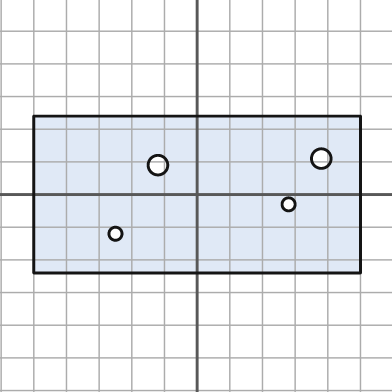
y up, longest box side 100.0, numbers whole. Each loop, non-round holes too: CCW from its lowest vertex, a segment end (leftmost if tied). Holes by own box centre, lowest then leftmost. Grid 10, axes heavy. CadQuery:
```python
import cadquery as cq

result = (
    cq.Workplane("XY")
    .moveTo(-50.0, -24.0)
    .lineTo(50.0, -24.0)
    .lineTo(50.0, 24.0)
    .lineTo(-50.0, 24.0)
    .close()
    .moveTo(-25.0, -12.0)
    .circle(2.0)
    .moveTo(28.0, -3.0)
    .circle(2.0)
    .moveTo(-12.0, 9.0)
    .circle(3.0)
    .moveTo(38.0, 11.0)
    .circle(3.0)
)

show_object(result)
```